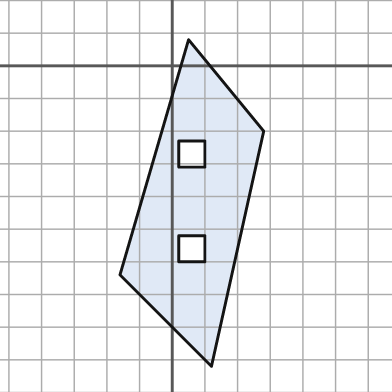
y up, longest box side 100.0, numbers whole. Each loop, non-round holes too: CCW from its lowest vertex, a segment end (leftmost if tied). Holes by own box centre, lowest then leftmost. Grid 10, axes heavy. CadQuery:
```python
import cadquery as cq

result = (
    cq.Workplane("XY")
    .moveTo(12.0, -92.0)
    .lineTo(28.0, -20.0)
    .lineTo(5.0, 8.0)
    .lineTo(-16.0, -64.0)
    .close()
    .moveTo(2.0, -60.0)
    .lineTo(10.0, -60.0)
    .lineTo(10.0, -52.0)
    .lineTo(2.0, -52.0)
    .close()
    .moveTo(2.0, -31.0)
    .lineTo(10.0, -31.0)
    .lineTo(10.0, -23.0)
    .lineTo(2.0, -23.0)
    .close()
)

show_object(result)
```